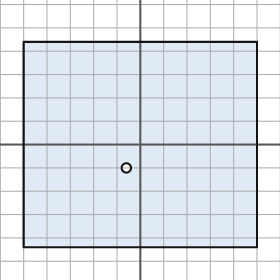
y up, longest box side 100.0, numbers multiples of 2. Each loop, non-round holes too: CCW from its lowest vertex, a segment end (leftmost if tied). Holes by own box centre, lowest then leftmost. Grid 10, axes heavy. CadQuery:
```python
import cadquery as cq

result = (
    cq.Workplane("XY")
    .moveTo(-50.0, -44.0)
    .lineTo(50.0, -44.0)
    .lineTo(50.0, 44.0)
    .lineTo(-50.0, 44.0)
    .close()
    .moveTo(-6.0, -10.0)
    .circle(2.0)
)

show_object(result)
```